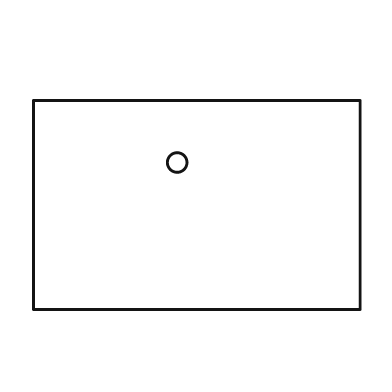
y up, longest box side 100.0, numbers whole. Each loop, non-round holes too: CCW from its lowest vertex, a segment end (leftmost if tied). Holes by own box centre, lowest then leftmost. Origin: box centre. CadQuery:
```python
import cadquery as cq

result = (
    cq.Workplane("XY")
    .moveTo(-50.0, -32.0)
    .lineTo(50.0, -32.0)
    .lineTo(50.0, 32.0)
    .lineTo(-50.0, 32.0)
    .close()
    .moveTo(-6.0, 13.0)
    .circle(3.0)
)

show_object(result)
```